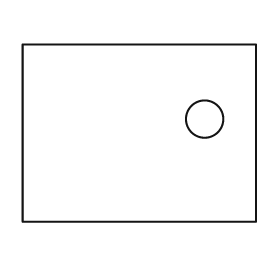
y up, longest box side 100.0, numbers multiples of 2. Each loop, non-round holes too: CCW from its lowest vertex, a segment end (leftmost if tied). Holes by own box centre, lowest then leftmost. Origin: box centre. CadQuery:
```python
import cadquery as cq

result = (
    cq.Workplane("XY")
    .moveTo(-50.0, -38.0)
    .lineTo(50.0, -38.0)
    .lineTo(50.0, 38.0)
    .lineTo(-50.0, 38.0)
    .close()
    .moveTo(28.0, 6.0)
    .circle(8.0)
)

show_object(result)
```